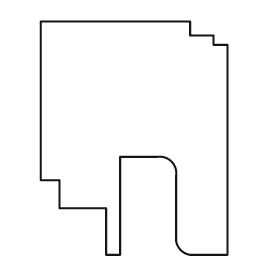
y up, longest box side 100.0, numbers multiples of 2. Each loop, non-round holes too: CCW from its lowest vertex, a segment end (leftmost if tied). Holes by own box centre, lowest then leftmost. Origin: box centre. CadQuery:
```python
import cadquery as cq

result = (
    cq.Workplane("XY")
    .moveTo(-12.0, -50.0)
    .lineTo(-6.0, -50.0)
    .lineTo(-6.0, -8.0)
    .lineTo(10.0, -8.0)
    .threePointArc((16.0, -10.0), (18.0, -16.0))
    .lineTo(18.0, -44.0)
    .threePointArc((20.0, -48.0), (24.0, -50.0))
    .lineTo(40.0, -50.0)
    .lineTo(40.0, 40.0)
    .lineTo(34.0, 40.0)
    .lineTo(34.0, 44.0)
    .lineTo(24.0, 44.0)
    .lineTo(24.0, 50.0)
    .lineTo(-40.0, 50.0)
    .lineTo(-40.0, -18.0)
    .lineTo(-32.0, -18.0)
    .lineTo(-32.0, -30.0)
    .lineTo(-12.0, -30.0)
    .close()
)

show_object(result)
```